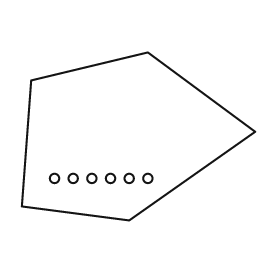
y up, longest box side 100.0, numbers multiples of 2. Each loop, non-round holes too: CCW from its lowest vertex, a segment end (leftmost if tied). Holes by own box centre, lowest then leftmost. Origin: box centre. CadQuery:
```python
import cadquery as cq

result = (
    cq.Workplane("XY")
    .moveTo(-4.0, -36.0)
    .lineTo(50.0, 2.0)
    .lineTo(4.0, 36.0)
    .lineTo(-46.0, 24.0)
    .lineTo(-50.0, -30.0)
    .close()
    .moveTo(-36.0, -18.0)
    .circle(2.0)
    .moveTo(-28.0, -18.0)
    .circle(2.0)
    .moveTo(-20.0, -18.0)
    .circle(2.0)
    .moveTo(-12.0, -18.0)
    .circle(2.0)
    .moveTo(-4.0, -18.0)
    .circle(2.0)
    .moveTo(4.0, -18.0)
    .circle(2.0)
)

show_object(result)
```